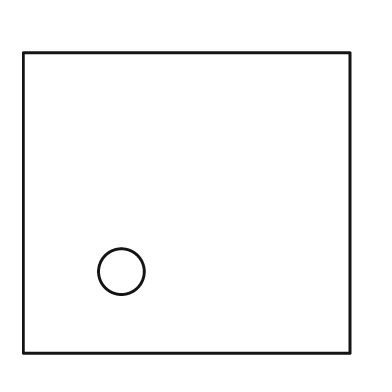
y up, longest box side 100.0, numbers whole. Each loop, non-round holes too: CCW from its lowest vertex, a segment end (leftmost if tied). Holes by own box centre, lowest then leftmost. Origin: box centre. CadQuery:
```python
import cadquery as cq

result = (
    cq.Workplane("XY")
    .moveTo(-50.0, -46.0)
    .lineTo(50.0, -46.0)
    .lineTo(50.0, 46.0)
    .lineTo(-50.0, 46.0)
    .close()
    .moveTo(-20.0, -21.0)
    .circle(7.0)
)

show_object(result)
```